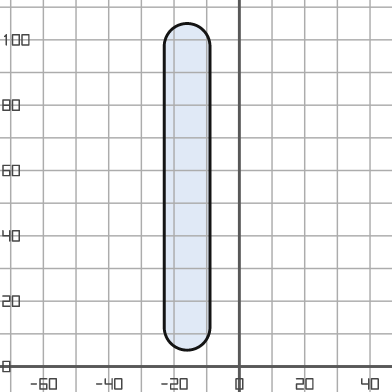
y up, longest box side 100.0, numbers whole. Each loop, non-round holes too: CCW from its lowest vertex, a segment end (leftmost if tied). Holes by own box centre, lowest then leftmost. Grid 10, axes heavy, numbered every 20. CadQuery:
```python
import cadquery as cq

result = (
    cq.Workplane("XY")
    .moveTo(-23.0, 12.0)
    .threePointArc((-16.0, 5.0), (-9.0, 12.0))
    .lineTo(-9.0, 98.0)
    .threePointArc((-16.0, 105.0), (-23.0, 98.0))
    .close()
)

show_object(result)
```